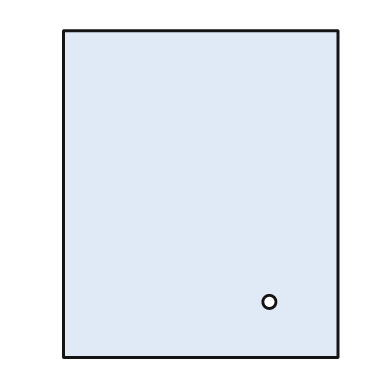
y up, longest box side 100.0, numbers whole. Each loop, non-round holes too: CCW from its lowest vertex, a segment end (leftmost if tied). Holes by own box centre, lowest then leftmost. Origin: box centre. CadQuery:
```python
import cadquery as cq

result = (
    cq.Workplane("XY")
    .moveTo(-42.0, -50.0)
    .lineTo(42.0, -50.0)
    .lineTo(42.0, 50.0)
    .lineTo(-42.0, 50.0)
    .close()
    .moveTo(21.0, -33.0)
    .circle(2.0)
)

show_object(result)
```